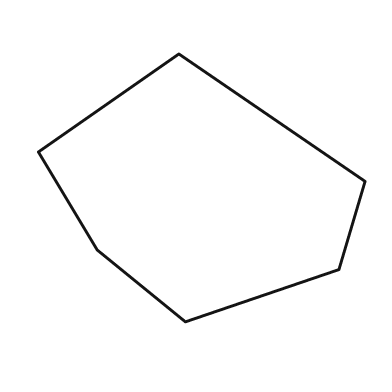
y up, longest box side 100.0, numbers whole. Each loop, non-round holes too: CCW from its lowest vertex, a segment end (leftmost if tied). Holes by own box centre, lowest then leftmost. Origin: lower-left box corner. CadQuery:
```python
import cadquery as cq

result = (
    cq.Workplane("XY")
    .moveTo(45.0, 0.0)
    .lineTo(92.0, 16.0)
    .lineTo(100.0, 43.0)
    .lineTo(43.0, 82.0)
    .lineTo(0.0, 52.0)
    .lineTo(18.0, 22.0)
    .close()
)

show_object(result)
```